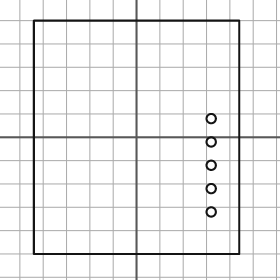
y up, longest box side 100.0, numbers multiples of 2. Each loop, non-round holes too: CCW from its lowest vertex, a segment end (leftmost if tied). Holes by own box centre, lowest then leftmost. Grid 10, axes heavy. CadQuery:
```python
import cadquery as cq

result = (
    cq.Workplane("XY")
    .moveTo(-44.0, -50.0)
    .lineTo(44.0, -50.0)
    .lineTo(44.0, 50.0)
    .lineTo(-44.0, 50.0)
    .close()
    .moveTo(32.0, -32.0)
    .circle(2.0)
    .moveTo(32.0, -22.0)
    .circle(2.0)
    .moveTo(32.0, -12.0)
    .circle(2.0)
    .moveTo(32.0, -2.0)
    .circle(2.0)
    .moveTo(32.0, 8.0)
    .circle(2.0)
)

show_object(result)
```